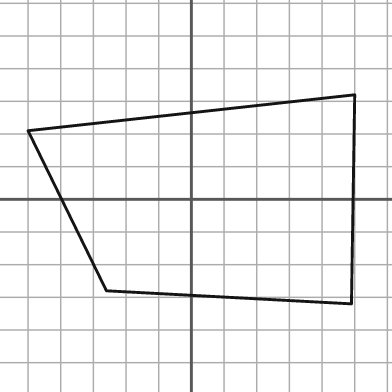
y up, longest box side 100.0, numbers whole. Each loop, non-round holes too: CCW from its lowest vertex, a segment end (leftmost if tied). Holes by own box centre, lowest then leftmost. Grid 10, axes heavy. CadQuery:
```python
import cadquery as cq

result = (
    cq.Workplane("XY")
    .moveTo(49.0, -32.0)
    .lineTo(50.0, 32.0)
    .lineTo(-50.0, 21.0)
    .lineTo(-26.0, -28.0)
    .close()
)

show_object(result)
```